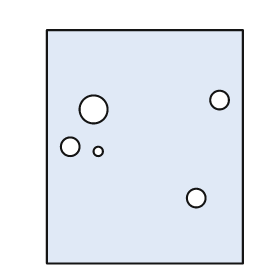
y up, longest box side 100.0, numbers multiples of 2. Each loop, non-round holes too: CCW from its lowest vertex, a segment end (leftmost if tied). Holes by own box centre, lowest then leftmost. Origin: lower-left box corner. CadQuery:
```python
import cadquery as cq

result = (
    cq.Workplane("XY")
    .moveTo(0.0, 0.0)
    .lineTo(84.0, 0.0)
    .lineTo(84.0, 100.0)
    .lineTo(0.0, 100.0)
    .close()
    .moveTo(64.0, 28.0)
    .circle(4.0)
    .moveTo(22.0, 48.0)
    .circle(2.0)
    .moveTo(10.0, 50.0)
    .circle(4.0)
    .moveTo(20.0, 66.0)
    .circle(6.0)
    .moveTo(74.0, 70.0)
    .circle(4.0)
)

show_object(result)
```